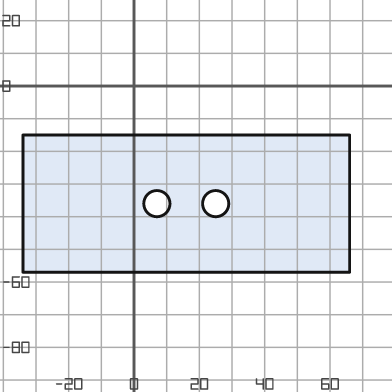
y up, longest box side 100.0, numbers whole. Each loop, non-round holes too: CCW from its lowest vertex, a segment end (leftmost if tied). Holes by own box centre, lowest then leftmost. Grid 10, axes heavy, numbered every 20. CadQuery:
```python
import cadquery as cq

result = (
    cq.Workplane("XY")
    .moveTo(-34.0, -57.0)
    .lineTo(66.0, -57.0)
    .lineTo(66.0, -15.0)
    .lineTo(-34.0, -15.0)
    .close()
    .moveTo(7.0, -36.0)
    .circle(4.0)
    .moveTo(25.0, -36.0)
    .circle(4.0)
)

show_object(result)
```